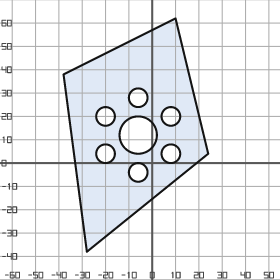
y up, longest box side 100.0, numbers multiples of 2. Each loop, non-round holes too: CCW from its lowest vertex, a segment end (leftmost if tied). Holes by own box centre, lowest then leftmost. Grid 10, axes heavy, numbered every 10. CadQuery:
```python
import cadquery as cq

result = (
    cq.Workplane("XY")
    .moveTo(-28.0, -38.0)
    .lineTo(24.0, 4.0)
    .lineTo(10.0, 62.0)
    .lineTo(-38.0, 38.0)
    .close()
    .moveTo(-6.0, -4.0)
    .circle(4.0)
    .moveTo(-20.0, 4.0)
    .circle(4.0)
    .moveTo(8.0, 4.0)
    .circle(4.0)
    .moveTo(-6.0, 12.0)
    .circle(8.0)
    .moveTo(-20.0, 20.0)
    .circle(4.0)
    .moveTo(8.0, 20.0)
    .circle(4.0)
    .moveTo(-6.0, 28.0)
    .circle(4.0)
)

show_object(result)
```